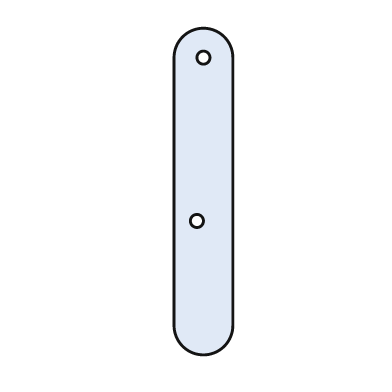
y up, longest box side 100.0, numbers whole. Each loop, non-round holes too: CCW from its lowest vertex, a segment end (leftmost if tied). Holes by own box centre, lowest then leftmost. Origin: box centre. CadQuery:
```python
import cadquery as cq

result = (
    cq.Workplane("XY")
    .moveTo(-9.0, -41.0)
    .threePointArc((0.0, -50.0), (9.0, -41.0))
    .lineTo(9.0, 41.0)
    .threePointArc((0.0, 50.0), (-9.0, 41.0))
    .close()
    .moveTo(-2.0, -9.0)
    .circle(2.0)
    .moveTo(0.0, 41.0)
    .circle(2.0)
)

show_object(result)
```